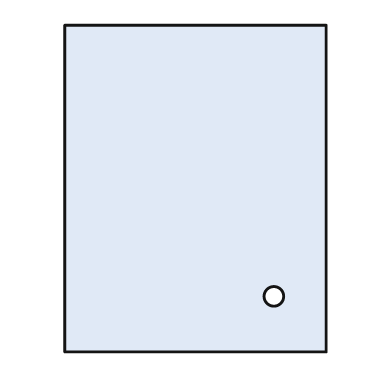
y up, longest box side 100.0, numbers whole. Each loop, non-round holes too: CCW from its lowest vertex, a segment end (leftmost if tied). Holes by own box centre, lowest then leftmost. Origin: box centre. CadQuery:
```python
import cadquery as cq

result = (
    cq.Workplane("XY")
    .moveTo(-40.0, -50.0)
    .lineTo(40.0, -50.0)
    .lineTo(40.0, 50.0)
    .lineTo(-40.0, 50.0)
    .close()
    .moveTo(24.0, -33.0)
    .circle(3.0)
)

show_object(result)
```